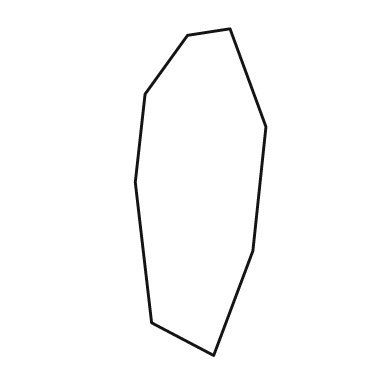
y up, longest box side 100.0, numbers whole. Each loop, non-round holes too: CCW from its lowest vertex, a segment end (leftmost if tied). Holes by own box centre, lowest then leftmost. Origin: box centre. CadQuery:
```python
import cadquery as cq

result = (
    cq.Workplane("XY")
    .moveTo(4.0, -50.0)
    .lineTo(16.0, -18.0)
    .lineTo(20.0, 20.0)
    .lineTo(9.0, 50.0)
    .lineTo(-4.0, 48.0)
    .lineTo(-17.0, 30.0)
    .lineTo(-20.0, 3.0)
    .lineTo(-15.0, -40.0)
    .close()
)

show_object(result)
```